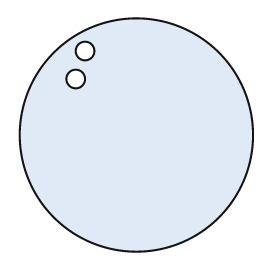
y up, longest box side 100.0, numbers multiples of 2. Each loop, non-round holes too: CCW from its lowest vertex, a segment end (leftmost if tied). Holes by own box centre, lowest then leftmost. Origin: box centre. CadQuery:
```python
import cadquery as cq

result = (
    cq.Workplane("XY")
    .moveTo(0.0, 0.0)
    .circle(50.0)
    .moveTo(-26.0, 24.0)
    .circle(4.0)
    .moveTo(-22.0, 36.0)
    .circle(4.0)
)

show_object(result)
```